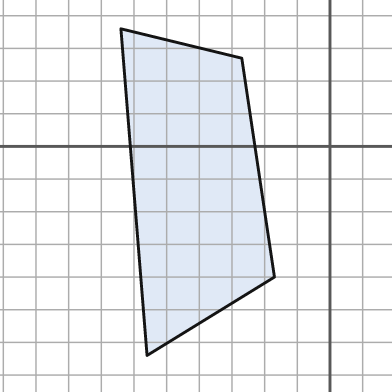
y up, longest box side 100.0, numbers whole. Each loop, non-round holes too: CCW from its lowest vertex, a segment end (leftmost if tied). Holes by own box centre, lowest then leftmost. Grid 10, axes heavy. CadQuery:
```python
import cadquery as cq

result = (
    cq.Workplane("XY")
    .moveTo(-56.0, -64.0)
    .lineTo(-17.0, -40.0)
    .lineTo(-27.0, 27.0)
    .lineTo(-64.0, 36.0)
    .close()
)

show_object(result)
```